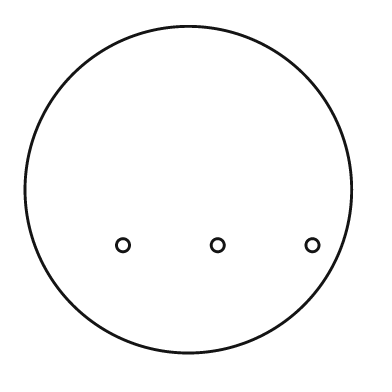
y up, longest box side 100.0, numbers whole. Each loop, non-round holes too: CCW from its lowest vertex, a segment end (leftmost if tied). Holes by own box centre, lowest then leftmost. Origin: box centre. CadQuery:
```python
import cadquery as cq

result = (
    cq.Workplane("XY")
    .moveTo(0.0, 0.0)
    .circle(50.0)
    .moveTo(-20.0, -17.0)
    .circle(2.0)
    .moveTo(9.0, -17.0)
    .circle(2.0)
    .moveTo(38.0, -17.0)
    .circle(2.0)
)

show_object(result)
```